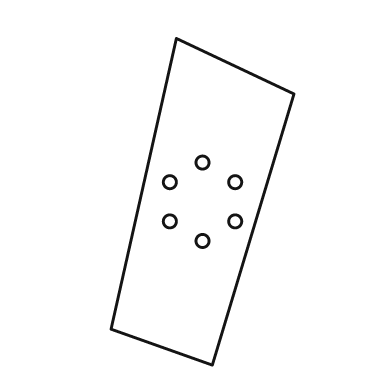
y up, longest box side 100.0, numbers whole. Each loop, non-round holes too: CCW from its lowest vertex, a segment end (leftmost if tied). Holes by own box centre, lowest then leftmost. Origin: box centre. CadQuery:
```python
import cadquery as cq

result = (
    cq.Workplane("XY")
    .moveTo(3.0, -50.0)
    .lineTo(28.0, 33.0)
    .lineTo(-8.0, 50.0)
    .lineTo(-28.0, -39.0)
    .close()
    .moveTo(0.0, -12.0)
    .circle(2.0)
    .moveTo(-10.0, -6.0)
    .circle(2.0)
    .moveTo(10.0, -6.0)
    .circle(2.0)
    .moveTo(-10.0, 6.0)
    .circle(2.0)
    .moveTo(10.0, 6.0)
    .circle(2.0)
    .moveTo(0.0, 12.0)
    .circle(2.0)
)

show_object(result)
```